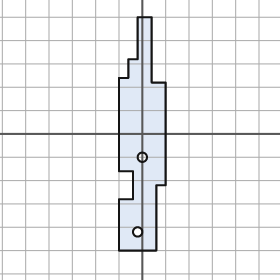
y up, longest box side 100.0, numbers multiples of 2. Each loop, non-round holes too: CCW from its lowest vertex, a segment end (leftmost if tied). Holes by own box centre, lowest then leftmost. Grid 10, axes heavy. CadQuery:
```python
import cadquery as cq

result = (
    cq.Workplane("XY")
    .moveTo(-10.0, -50.0)
    .lineTo(6.0, -50.0)
    .lineTo(6.0, -22.0)
    .lineTo(10.0, -22.0)
    .lineTo(10.0, 22.0)
    .lineTo(4.0, 22.0)
    .lineTo(4.0, 50.0)
    .lineTo(-2.0, 50.0)
    .lineTo(-2.0, 32.0)
    .lineTo(-6.0, 32.0)
    .lineTo(-6.0, 24.0)
    .lineTo(-10.0, 24.0)
    .lineTo(-10.0, -16.0)
    .lineTo(-4.0, -16.0)
    .lineTo(-4.0, -28.0)
    .lineTo(-10.0, -28.0)
    .close()
    .moveTo(-2.0, -42.0)
    .circle(2.0)
    .moveTo(0.0, -10.0)
    .circle(2.0)
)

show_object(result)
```